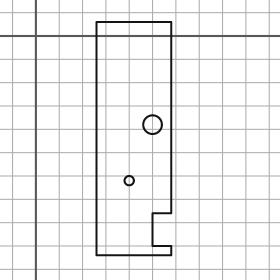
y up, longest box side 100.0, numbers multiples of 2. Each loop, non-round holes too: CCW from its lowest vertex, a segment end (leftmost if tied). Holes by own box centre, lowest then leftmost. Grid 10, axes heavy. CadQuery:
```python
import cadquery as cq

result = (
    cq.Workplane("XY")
    .moveTo(26.0, -94.0)
    .lineTo(58.0, -94.0)
    .lineTo(58.0, -90.0)
    .lineTo(50.0, -90.0)
    .lineTo(50.0, -76.0)
    .lineTo(58.0, -76.0)
    .lineTo(58.0, 6.0)
    .lineTo(26.0, 6.0)
    .close()
    .moveTo(40.0, -62.0)
    .circle(2.0)
    .moveTo(50.0, -38.0)
    .circle(4.0)
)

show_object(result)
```